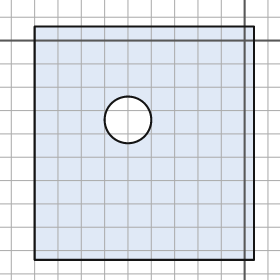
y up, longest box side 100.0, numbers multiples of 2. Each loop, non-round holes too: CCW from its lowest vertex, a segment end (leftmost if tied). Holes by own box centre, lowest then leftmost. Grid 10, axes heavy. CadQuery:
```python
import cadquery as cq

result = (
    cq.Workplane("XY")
    .moveTo(-90.0, -94.0)
    .lineTo(4.0, -94.0)
    .lineTo(4.0, 6.0)
    .lineTo(-90.0, 6.0)
    .close()
    .moveTo(-50.0, -34.0)
    .circle(10.0)
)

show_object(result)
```